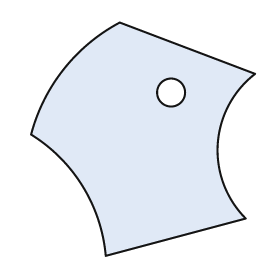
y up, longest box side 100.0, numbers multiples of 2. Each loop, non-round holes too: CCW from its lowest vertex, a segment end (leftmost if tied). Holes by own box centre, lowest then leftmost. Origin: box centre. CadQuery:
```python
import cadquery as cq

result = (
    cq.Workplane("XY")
    .moveTo(-16.0, -50.0)
    .lineTo(44.0, -34.0)
    .threePointArc((32.0, -2.0), (48.0, 28.0))
    .lineTo(-10.0, 50.0)
    .threePointArc((-34.0, 30.0), (-48.0, 2.0))
    .threePointArc((-26.0, -20.0), (-16.0, -50.0))
    .close()
    .moveTo(12.0, 20.0)
    .circle(6.0)
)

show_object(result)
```